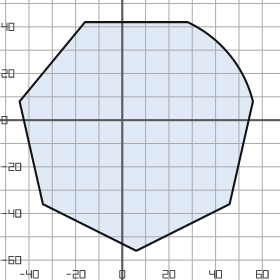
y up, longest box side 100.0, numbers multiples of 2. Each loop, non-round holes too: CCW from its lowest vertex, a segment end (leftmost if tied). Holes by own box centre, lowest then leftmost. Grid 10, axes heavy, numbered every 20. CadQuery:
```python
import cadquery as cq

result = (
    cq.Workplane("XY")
    .moveTo(6.0, -56.0)
    .lineTo(46.0, -36.0)
    .lineTo(56.0, 8.0)
    .threePointArc((46.0, 28.0), (28.0, 42.0))
    .lineTo(-16.0, 42.0)
    .lineTo(-44.0, 8.0)
    .lineTo(-34.0, -36.0)
    .close()
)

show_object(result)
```